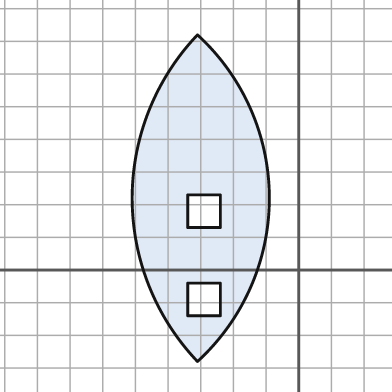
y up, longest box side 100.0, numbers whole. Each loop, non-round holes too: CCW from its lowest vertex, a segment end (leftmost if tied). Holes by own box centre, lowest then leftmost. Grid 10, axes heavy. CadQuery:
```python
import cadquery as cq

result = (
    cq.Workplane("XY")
    .moveTo(-31.0, -28.0)
    .threePointArc((-9.0, 22.0), (-31.0, 72.0))
    .threePointArc((-51.0, 22.0), (-31.0, -28.0))
    .close()
    .moveTo(-34.0, -14.0)
    .lineTo(-24.0, -14.0)
    .lineTo(-24.0, -4.0)
    .lineTo(-34.0, -4.0)
    .close()
    .moveTo(-34.0, 13.0)
    .lineTo(-24.0, 13.0)
    .lineTo(-24.0, 23.0)
    .lineTo(-34.0, 23.0)
    .close()
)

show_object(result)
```